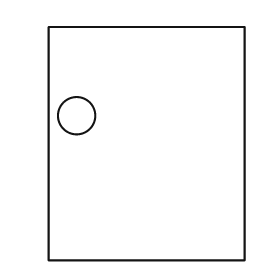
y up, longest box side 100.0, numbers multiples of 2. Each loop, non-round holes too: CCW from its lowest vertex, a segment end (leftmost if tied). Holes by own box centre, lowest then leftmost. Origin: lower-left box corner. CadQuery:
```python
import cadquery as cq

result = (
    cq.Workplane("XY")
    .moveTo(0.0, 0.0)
    .lineTo(84.0, 0.0)
    .lineTo(84.0, 100.0)
    .lineTo(0.0, 100.0)
    .close()
    .moveTo(12.0, 62.0)
    .circle(8.0)
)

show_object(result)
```